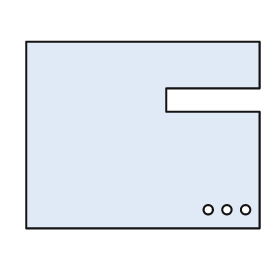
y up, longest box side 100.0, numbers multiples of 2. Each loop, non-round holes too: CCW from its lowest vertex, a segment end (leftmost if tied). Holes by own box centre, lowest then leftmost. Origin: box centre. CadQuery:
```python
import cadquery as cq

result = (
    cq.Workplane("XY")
    .moveTo(-50.0, -40.0)
    .lineTo(50.0, -40.0)
    .lineTo(50.0, 10.0)
    .lineTo(10.0, 10.0)
    .lineTo(10.0, 20.0)
    .lineTo(50.0, 20.0)
    .lineTo(50.0, 40.0)
    .lineTo(-50.0, 40.0)
    .close()
    .moveTo(28.0, -32.0)
    .circle(2.0)
    .moveTo(36.0, -32.0)
    .circle(2.0)
    .moveTo(44.0, -32.0)
    .circle(2.0)
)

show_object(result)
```